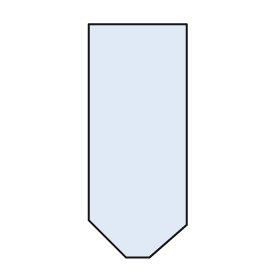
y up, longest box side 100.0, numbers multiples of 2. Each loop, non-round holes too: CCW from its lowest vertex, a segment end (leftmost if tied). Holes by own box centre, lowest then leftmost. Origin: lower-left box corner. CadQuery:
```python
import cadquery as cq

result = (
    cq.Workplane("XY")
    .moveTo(16.0, 0.0)
    .lineTo(26.0, 0.0)
    .lineTo(42.0, 14.0)
    .lineTo(42.0, 100.0)
    .lineTo(0.0, 100.0)
    .lineTo(0.0, 16.0)
    .close()
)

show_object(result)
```